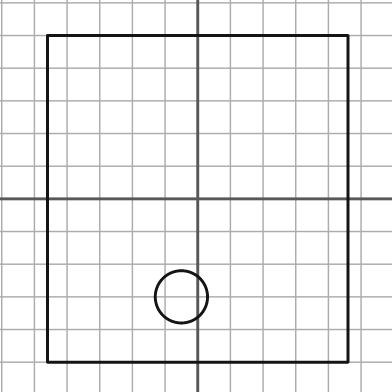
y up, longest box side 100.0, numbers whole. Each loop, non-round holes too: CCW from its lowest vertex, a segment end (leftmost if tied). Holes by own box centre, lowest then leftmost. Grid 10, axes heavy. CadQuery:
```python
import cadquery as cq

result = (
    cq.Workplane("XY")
    .moveTo(-46.0, -50.0)
    .lineTo(46.0, -50.0)
    .lineTo(46.0, 50.0)
    .lineTo(-46.0, 50.0)
    .close()
    .moveTo(-5.0, -30.0)
    .circle(8.0)
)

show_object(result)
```